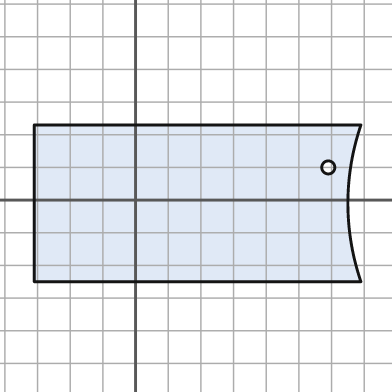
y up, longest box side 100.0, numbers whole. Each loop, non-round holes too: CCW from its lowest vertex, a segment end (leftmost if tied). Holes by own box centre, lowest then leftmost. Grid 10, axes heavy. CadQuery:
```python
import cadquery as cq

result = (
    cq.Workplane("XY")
    .moveTo(-31.0, -25.0)
    .lineTo(69.0, -25.0)
    .threePointArc((65.0, -1.0), (69.0, 23.0))
    .lineTo(-31.0, 23.0)
    .close()
    .moveTo(59.0, 10.0)
    .circle(2.0)
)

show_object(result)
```